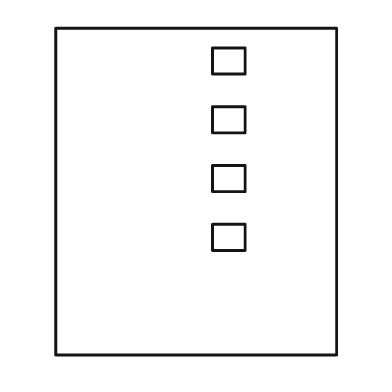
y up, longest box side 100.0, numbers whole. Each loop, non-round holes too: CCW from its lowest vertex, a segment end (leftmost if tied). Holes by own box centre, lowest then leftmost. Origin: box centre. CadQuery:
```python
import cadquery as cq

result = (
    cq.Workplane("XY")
    .moveTo(-43.0, -50.0)
    .lineTo(43.0, -50.0)
    .lineTo(43.0, 50.0)
    .lineTo(-43.0, 50.0)
    .close()
    .moveTo(5.0, -18.0)
    .lineTo(15.0, -18.0)
    .lineTo(15.0, -10.0)
    .lineTo(5.0, -10.0)
    .close()
    .moveTo(5.0, 0.0)
    .lineTo(15.0, 0.0)
    .lineTo(15.0, 8.0)
    .lineTo(5.0, 8.0)
    .close()
    .moveTo(5.0, 18.0)
    .lineTo(15.0, 18.0)
    .lineTo(15.0, 26.0)
    .lineTo(5.0, 26.0)
    .close()
    .moveTo(5.0, 36.0)
    .lineTo(15.0, 36.0)
    .lineTo(15.0, 44.0)
    .lineTo(5.0, 44.0)
    .close()
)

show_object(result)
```